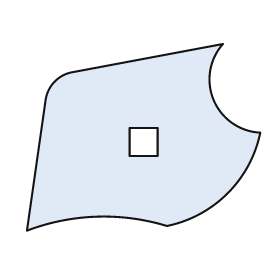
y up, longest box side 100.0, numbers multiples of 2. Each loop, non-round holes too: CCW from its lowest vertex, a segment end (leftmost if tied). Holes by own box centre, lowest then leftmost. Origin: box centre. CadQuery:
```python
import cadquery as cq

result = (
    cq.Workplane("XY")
    .moveTo(-50.0, -40.0)
    .threePointArc((-20.0, -34.0), (10.0, -38.0))
    .threePointArc((36.0, -24.0), (50.0, 2.0))
    .threePointArc((30.0, 16.0), (34.0, 40.0))
    .lineTo(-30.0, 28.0)
    .threePointArc((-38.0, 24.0), (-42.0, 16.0))
    .close()
    .moveTo(-6.0, -8.0)
    .lineTo(6.0, -8.0)
    .lineTo(6.0, 4.0)
    .lineTo(-6.0, 4.0)
    .close()
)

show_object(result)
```